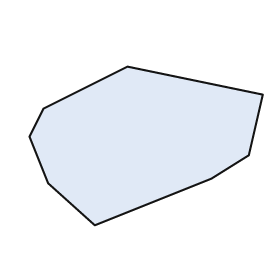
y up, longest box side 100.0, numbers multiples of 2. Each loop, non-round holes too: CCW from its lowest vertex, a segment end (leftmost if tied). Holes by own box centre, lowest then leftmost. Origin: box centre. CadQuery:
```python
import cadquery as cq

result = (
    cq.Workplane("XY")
    .moveTo(-22.0, -34.0)
    .lineTo(28.0, -14.0)
    .lineTo(44.0, -4.0)
    .lineTo(50.0, 22.0)
    .lineTo(-8.0, 34.0)
    .lineTo(-44.0, 16.0)
    .lineTo(-50.0, 4.0)
    .lineTo(-42.0, -16.0)
    .close()
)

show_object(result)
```